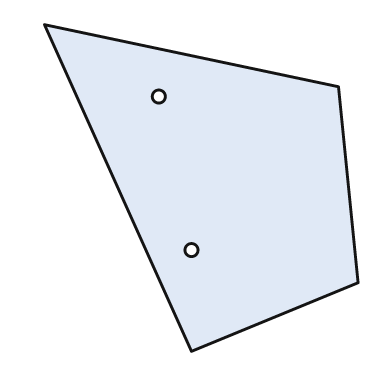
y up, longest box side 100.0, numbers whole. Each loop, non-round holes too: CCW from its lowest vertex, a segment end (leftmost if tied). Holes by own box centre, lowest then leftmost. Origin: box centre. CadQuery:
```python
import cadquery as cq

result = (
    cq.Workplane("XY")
    .moveTo(-3.0, -50.0)
    .lineTo(48.0, -29.0)
    .lineTo(42.0, 31.0)
    .lineTo(-48.0, 50.0)
    .close()
    .moveTo(-3.0, -19.0)
    .circle(2.0)
    .moveTo(-13.0, 28.0)
    .circle(2.0)
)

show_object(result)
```